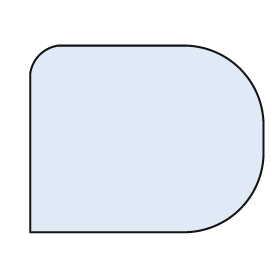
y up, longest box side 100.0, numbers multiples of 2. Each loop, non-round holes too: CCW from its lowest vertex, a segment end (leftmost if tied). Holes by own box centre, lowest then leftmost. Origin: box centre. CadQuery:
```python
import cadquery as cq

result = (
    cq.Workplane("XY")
    .moveTo(-50.0, -40.0)
    .lineTo(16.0, -40.0)
    .threePointArc((40.0, -30.0), (50.0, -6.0))
    .lineTo(50.0, 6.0)
    .threePointArc((40.0, 30.0), (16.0, 40.0))
    .lineTo(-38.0, 40.0)
    .threePointArc((-46.0, 36.0), (-50.0, 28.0))
    .close()
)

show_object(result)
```